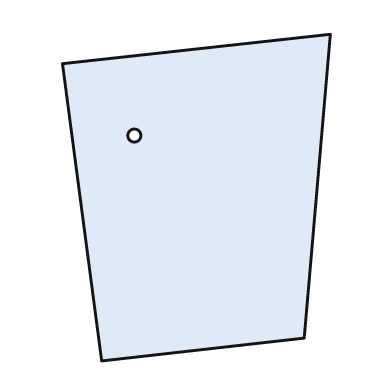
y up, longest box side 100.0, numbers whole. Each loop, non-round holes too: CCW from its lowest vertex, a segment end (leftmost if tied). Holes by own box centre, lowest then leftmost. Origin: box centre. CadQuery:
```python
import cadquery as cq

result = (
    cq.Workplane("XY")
    .moveTo(-29.0, -50.0)
    .lineTo(33.0, -43.0)
    .lineTo(41.0, 50.0)
    .lineTo(-41.0, 41.0)
    .close()
    .moveTo(-19.0, 19.0)
    .circle(2.0)
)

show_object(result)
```